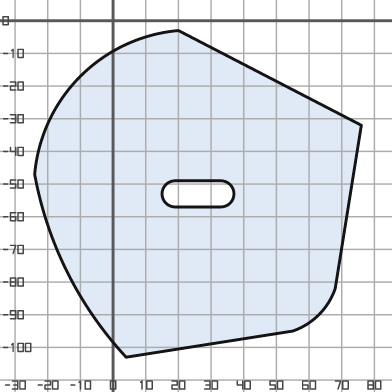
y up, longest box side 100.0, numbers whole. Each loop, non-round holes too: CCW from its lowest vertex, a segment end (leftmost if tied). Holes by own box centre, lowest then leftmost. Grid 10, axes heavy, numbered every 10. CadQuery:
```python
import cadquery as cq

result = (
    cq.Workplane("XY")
    .moveTo(4.0, -103.0)
    .lineTo(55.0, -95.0)
    .threePointArc((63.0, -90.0), (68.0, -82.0))
    .lineTo(76.0, -32.0)
    .lineTo(20.0, -3.0)
    .threePointArc((-10.0, -17.0), (-24.0, -47.0))
    .threePointArc((-14.0, -77.0), (4.0, -103.0))
    .close()
    .moveTo(19.0, -57.0)
    .lineTo(33.0, -57.0)
    .threePointArc((37.0, -53.0), (33.0, -49.0))
    .lineTo(19.0, -49.0)
    .threePointArc((15.0, -53.0), (19.0, -57.0))
    .close()
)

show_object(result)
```